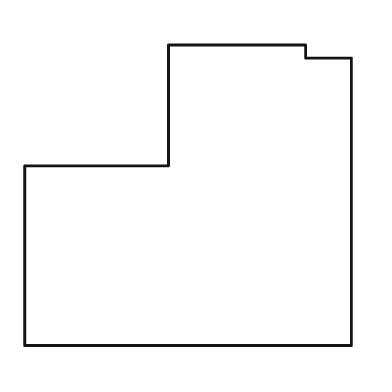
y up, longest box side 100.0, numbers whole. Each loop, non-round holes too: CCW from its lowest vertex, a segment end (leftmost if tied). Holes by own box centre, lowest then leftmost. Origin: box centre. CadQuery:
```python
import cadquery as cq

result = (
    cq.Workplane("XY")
    .moveTo(-50.0, -46.0)
    .lineTo(50.0, -46.0)
    .lineTo(50.0, 42.0)
    .lineTo(36.0, 42.0)
    .lineTo(36.0, 46.0)
    .lineTo(-6.0, 46.0)
    .lineTo(-6.0, 9.0)
    .lineTo(-50.0, 9.0)
    .close()
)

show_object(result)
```